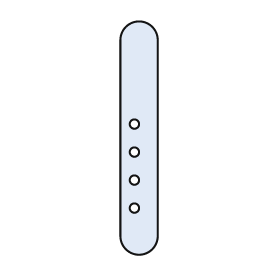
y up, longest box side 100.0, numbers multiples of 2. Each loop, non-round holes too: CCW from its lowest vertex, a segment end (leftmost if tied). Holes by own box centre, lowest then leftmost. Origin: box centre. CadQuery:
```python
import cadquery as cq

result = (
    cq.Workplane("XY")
    .moveTo(-8.0, -42.0)
    .threePointArc((0.0, -50.0), (8.0, -42.0))
    .lineTo(8.0, 42.0)
    .threePointArc((0.0, 50.0), (-8.0, 42.0))
    .close()
    .moveTo(-2.0, -30.0)
    .circle(2.0)
    .moveTo(-2.0, -18.0)
    .circle(2.0)
    .moveTo(-2.0, -6.0)
    .circle(2.0)
    .moveTo(-2.0, 6.0)
    .circle(2.0)
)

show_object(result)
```